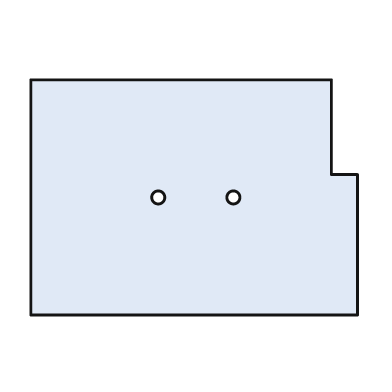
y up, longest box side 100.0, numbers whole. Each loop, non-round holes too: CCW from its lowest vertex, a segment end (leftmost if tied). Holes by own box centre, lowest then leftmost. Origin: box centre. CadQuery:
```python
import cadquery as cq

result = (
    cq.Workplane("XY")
    .moveTo(-50.0, -36.0)
    .lineTo(50.0, -36.0)
    .lineTo(50.0, 7.0)
    .lineTo(42.0, 7.0)
    .lineTo(42.0, 36.0)
    .lineTo(-50.0, 36.0)
    .close()
    .moveTo(-11.0, 0.0)
    .circle(2.0)
    .moveTo(12.0, 0.0)
    .circle(2.0)
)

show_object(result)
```